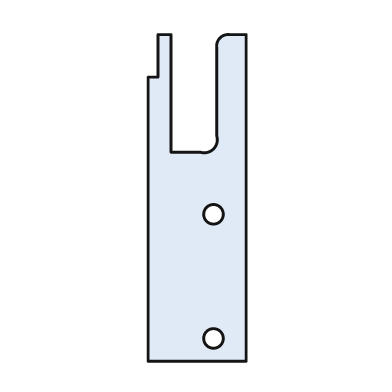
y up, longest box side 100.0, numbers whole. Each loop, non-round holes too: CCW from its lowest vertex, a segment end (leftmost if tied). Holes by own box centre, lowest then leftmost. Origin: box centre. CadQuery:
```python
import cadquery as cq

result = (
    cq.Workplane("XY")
    .moveTo(-15.0, -50.0)
    .lineTo(15.0, -50.0)
    .lineTo(15.0, 50.0)
    .lineTo(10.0, 50.0)
    .threePointArc((7.0, 49.0), (6.0, 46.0))
    .lineTo(6.0, 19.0)
    .threePointArc((5.0, 15.0), (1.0, 14.0))
    .lineTo(-8.0, 14.0)
    .lineTo(-8.0, 50.0)
    .lineTo(-12.0, 50.0)
    .lineTo(-12.0, 37.0)
    .lineTo(-15.0, 37.0)
    .close()
    .moveTo(5.0, -43.0)
    .circle(3.0)
    .moveTo(5.0, -5.0)
    .circle(3.0)
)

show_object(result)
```